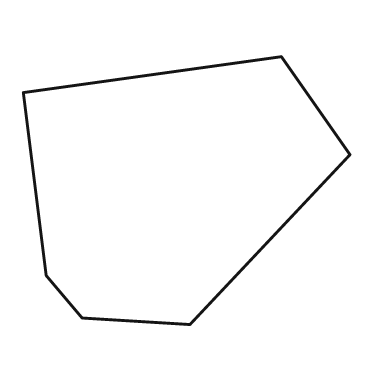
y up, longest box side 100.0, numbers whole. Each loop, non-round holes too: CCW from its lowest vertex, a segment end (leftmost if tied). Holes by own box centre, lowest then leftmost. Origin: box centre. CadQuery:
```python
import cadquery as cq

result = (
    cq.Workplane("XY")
    .moveTo(1.0, -41.0)
    .lineTo(50.0, 11.0)
    .lineTo(29.0, 41.0)
    .lineTo(-50.0, 30.0)
    .lineTo(-43.0, -26.0)
    .lineTo(-32.0, -39.0)
    .close()
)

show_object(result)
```